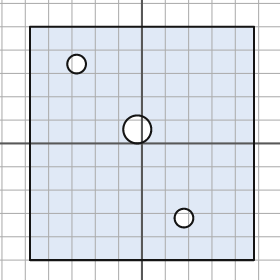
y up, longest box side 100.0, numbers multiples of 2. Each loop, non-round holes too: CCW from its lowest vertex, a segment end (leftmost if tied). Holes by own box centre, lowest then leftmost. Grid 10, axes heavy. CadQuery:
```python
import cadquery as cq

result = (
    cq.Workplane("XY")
    .moveTo(-48.0, -50.0)
    .lineTo(48.0, -50.0)
    .lineTo(48.0, 50.0)
    .lineTo(-48.0, 50.0)
    .close()
    .moveTo(18.0, -32.0)
    .circle(4.0)
    .moveTo(-2.0, 6.0)
    .circle(6.0)
    .moveTo(-28.0, 34.0)
    .circle(4.0)
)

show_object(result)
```